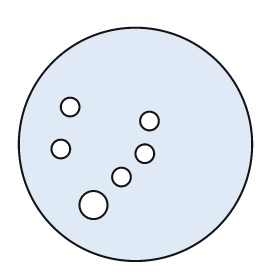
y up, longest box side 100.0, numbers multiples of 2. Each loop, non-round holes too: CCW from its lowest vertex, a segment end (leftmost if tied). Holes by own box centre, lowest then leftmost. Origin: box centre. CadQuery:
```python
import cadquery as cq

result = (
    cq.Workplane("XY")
    .moveTo(0.0, 0.0)
    .circle(50.0)
    .moveTo(-18.0, -26.0)
    .circle(6.0)
    .moveTo(-6.0, -14.0)
    .circle(4.0)
    .moveTo(4.0, -4.0)
    .circle(4.0)
    .moveTo(-32.0, -2.0)
    .circle(4.0)
    .moveTo(6.0, 10.0)
    .circle(4.0)
    .moveTo(-28.0, 16.0)
    .circle(4.0)
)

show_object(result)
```